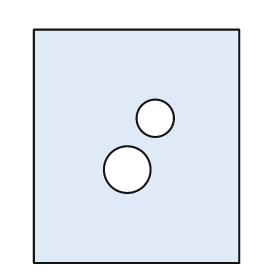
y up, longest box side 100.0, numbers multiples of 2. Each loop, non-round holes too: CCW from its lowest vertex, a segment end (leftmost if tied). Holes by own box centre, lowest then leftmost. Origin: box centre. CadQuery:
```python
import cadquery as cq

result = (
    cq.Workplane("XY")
    .moveTo(-44.0, -50.0)
    .lineTo(44.0, -50.0)
    .lineTo(44.0, 50.0)
    .lineTo(-44.0, 50.0)
    .close()
    .moveTo(-4.0, -10.0)
    .circle(10.0)
    .moveTo(8.0, 12.0)
    .circle(8.0)
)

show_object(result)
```